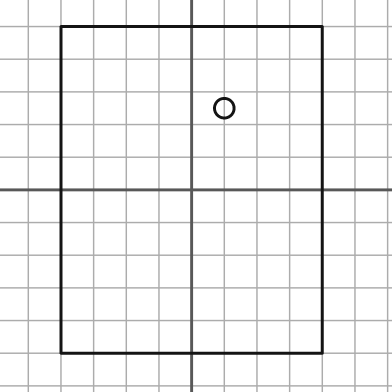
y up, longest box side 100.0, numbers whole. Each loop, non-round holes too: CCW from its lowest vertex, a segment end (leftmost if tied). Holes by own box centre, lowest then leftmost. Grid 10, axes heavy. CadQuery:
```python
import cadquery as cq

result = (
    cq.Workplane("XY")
    .moveTo(-40.0, -50.0)
    .lineTo(40.0, -50.0)
    .lineTo(40.0, 50.0)
    .lineTo(-40.0, 50.0)
    .close()
    .moveTo(10.0, 25.0)
    .circle(3.0)
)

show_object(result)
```